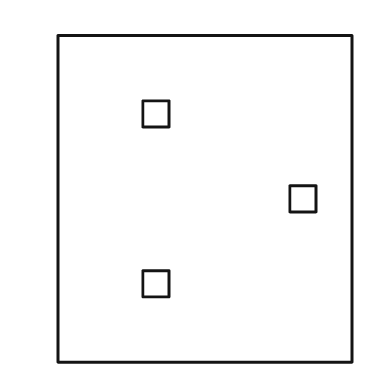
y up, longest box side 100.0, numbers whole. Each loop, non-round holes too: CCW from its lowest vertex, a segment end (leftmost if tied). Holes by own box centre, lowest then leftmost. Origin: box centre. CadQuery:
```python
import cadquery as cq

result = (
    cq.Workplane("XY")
    .moveTo(-45.0, -50.0)
    .lineTo(45.0, -50.0)
    .lineTo(45.0, 50.0)
    .lineTo(-45.0, 50.0)
    .close()
    .moveTo(-19.0, -30.0)
    .lineTo(-11.0, -30.0)
    .lineTo(-11.0, -22.0)
    .lineTo(-19.0, -22.0)
    .close()
    .moveTo(26.0, -4.0)
    .lineTo(34.0, -4.0)
    .lineTo(34.0, 4.0)
    .lineTo(26.0, 4.0)
    .close()
    .moveTo(-19.0, 22.0)
    .lineTo(-11.0, 22.0)
    .lineTo(-11.0, 30.0)
    .lineTo(-19.0, 30.0)
    .close()
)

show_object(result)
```